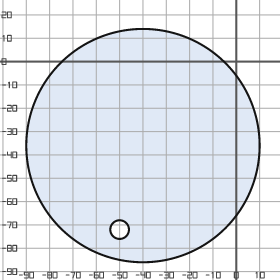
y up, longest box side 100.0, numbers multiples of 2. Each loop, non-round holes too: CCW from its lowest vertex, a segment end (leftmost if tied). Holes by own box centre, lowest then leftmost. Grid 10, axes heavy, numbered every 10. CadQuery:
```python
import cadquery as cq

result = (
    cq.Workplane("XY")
    .moveTo(-40.0, -36.0)
    .circle(50.0)
    .moveTo(-50.0, -72.0)
    .circle(4.0)
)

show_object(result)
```